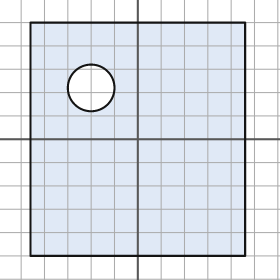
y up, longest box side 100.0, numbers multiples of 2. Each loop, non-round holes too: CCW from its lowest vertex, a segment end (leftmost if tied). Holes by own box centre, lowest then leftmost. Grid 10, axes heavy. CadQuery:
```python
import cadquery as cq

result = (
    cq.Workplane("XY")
    .moveTo(-46.0, -50.0)
    .lineTo(46.0, -50.0)
    .lineTo(46.0, 50.0)
    .lineTo(-46.0, 50.0)
    .close()
    .moveTo(-20.0, 22.0)
    .circle(10.0)
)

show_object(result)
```